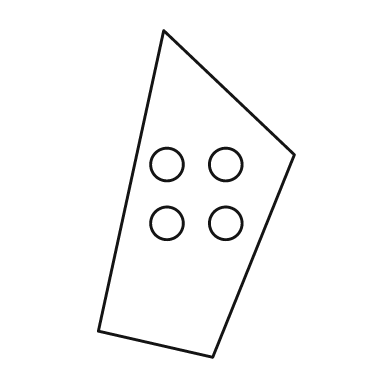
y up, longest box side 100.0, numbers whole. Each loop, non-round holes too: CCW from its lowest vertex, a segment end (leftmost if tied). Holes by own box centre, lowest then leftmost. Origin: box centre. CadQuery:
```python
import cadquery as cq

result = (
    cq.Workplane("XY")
    .moveTo(5.0, -50.0)
    .lineTo(30.0, 12.0)
    .lineTo(-10.0, 50.0)
    .lineTo(-30.0, -42.0)
    .close()
    .moveTo(-9.0, -9.0)
    .circle(5.0)
    .moveTo(9.0, -9.0)
    .circle(5.0)
    .moveTo(-9.0, 9.0)
    .circle(5.0)
    .moveTo(9.0, 9.0)
    .circle(5.0)
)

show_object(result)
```